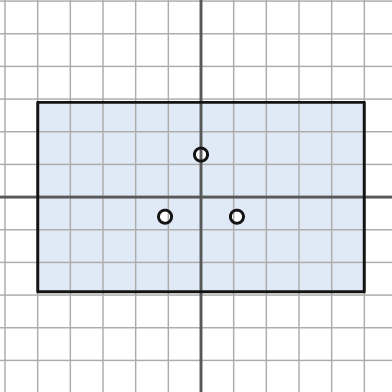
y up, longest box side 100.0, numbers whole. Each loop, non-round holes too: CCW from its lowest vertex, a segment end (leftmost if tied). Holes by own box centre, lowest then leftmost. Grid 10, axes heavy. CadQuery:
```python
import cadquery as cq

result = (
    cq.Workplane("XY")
    .moveTo(-50.0, -29.0)
    .lineTo(50.0, -29.0)
    .lineTo(50.0, 29.0)
    .lineTo(-50.0, 29.0)
    .close()
    .moveTo(-11.0, -6.0)
    .circle(2.0)
    .moveTo(11.0, -6.0)
    .circle(2.0)
    .moveTo(0.0, 13.0)
    .circle(2.0)
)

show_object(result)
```